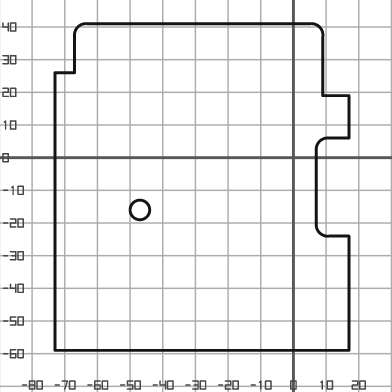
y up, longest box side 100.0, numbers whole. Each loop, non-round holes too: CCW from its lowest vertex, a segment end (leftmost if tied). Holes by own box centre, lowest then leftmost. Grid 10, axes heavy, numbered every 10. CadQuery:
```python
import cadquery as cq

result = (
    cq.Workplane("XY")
    .moveTo(-73.0, -59.0)
    .lineTo(17.0, -59.0)
    .lineTo(17.0, -24.0)
    .lineTo(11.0, -24.0)
    .threePointArc((8.0, -23.0), (7.0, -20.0))
    .lineTo(7.0, 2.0)
    .threePointArc((8.0, 5.0), (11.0, 6.0))
    .lineTo(17.0, 6.0)
    .lineTo(17.0, 19.0)
    .lineTo(9.0, 19.0)
    .lineTo(9.0, 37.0)
    .threePointArc((8.0, 40.0), (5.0, 41.0))
    .lineTo(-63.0, 41.0)
    .threePointArc((-66.0, 40.0), (-67.0, 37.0))
    .lineTo(-67.0, 26.0)
    .lineTo(-73.0, 26.0)
    .close()
    .moveTo(-47.0, -16.0)
    .circle(3.0)
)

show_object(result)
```